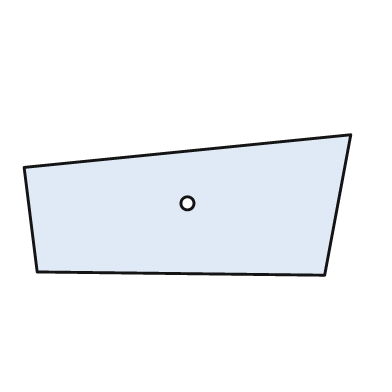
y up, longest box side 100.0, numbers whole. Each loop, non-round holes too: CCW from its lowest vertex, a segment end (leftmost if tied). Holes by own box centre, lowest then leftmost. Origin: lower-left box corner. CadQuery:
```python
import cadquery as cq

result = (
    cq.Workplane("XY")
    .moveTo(92.0, 0.0)
    .lineTo(100.0, 43.0)
    .lineTo(0.0, 33.0)
    .lineTo(4.0, 1.0)
    .close()
    .moveTo(50.0, 22.0)
    .circle(2.0)
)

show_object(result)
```